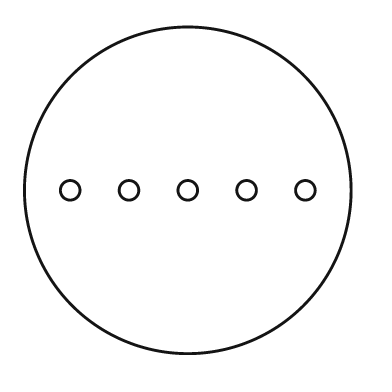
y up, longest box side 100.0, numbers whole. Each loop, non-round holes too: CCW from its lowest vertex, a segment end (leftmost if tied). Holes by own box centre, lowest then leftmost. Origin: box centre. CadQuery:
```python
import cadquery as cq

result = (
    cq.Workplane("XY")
    .moveTo(0.0, 0.0)
    .circle(50.0)
    .moveTo(-36.0, 0.0)
    .circle(3.0)
    .moveTo(-18.0, 0.0)
    .circle(3.0)
    .moveTo(0.0, 0.0)
    .circle(3.0)
    .moveTo(18.0, 0.0)
    .circle(3.0)
    .moveTo(36.0, 0.0)
    .circle(3.0)
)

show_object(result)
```